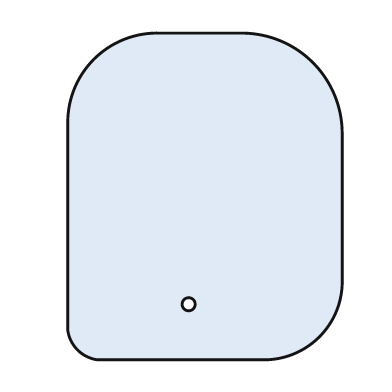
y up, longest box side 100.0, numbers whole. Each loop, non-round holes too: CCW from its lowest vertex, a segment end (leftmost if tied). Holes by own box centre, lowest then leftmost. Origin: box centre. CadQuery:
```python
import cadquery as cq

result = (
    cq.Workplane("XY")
    .moveTo(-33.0, -50.0)
    .lineTo(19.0, -50.0)
    .threePointArc((35.0, -43.0), (42.0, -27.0))
    .lineTo(42.0, 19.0)
    .threePointArc((33.0, 41.0), (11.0, 50.0))
    .lineTo(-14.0, 50.0)
    .threePointArc((-34.0, 42.0), (-42.0, 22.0))
    .lineTo(-42.0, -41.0)
    .threePointArc((-39.0, -47.0), (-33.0, -50.0))
    .close()
    .moveTo(-5.0, -33.0)
    .circle(2.0)
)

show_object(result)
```